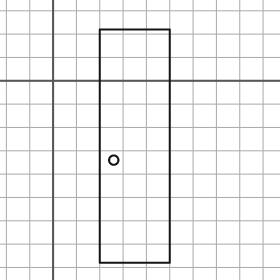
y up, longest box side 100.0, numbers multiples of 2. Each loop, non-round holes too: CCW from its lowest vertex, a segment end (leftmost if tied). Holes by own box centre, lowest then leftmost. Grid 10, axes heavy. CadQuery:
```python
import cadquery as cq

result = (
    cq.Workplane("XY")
    .moveTo(20.0, -78.0)
    .lineTo(50.0, -78.0)
    .lineTo(50.0, 22.0)
    .lineTo(20.0, 22.0)
    .close()
    .moveTo(26.0, -34.0)
    .circle(2.0)
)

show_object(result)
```